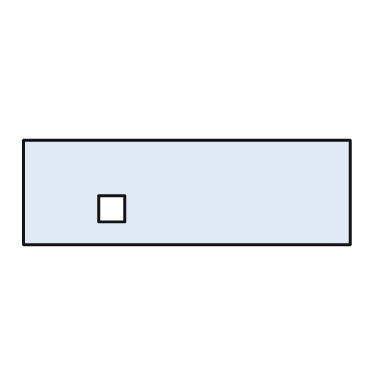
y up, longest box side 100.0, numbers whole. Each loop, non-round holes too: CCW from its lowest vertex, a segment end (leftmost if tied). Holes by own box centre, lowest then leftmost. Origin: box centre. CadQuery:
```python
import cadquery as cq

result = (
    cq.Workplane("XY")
    .moveTo(-50.0, -16.0)
    .lineTo(50.0, -16.0)
    .lineTo(50.0, 16.0)
    .lineTo(-50.0, 16.0)
    .close()
    .moveTo(-27.0, -9.0)
    .lineTo(-19.0, -9.0)
    .lineTo(-19.0, -1.0)
    .lineTo(-27.0, -1.0)
    .close()
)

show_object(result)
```